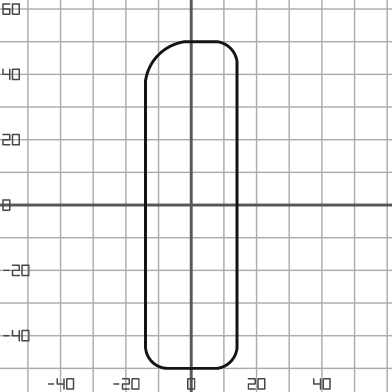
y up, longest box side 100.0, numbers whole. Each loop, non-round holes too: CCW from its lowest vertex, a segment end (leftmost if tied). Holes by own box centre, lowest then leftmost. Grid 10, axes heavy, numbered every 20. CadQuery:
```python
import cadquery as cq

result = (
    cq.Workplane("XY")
    .moveTo(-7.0, -50.0)
    .lineTo(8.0, -50.0)
    .threePointArc((12.0, -48.0), (14.0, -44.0))
    .lineTo(14.0, 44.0)
    .threePointArc((12.0, 48.0), (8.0, 50.0))
    .lineTo(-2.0, 50.0)
    .threePointArc((-10.0, 46.0), (-14.0, 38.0))
    .lineTo(-14.0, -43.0)
    .threePointArc((-12.0, -48.0), (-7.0, -50.0))
    .close()
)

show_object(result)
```